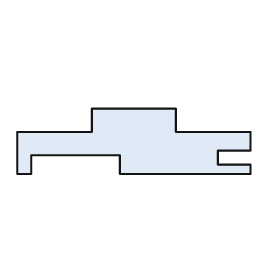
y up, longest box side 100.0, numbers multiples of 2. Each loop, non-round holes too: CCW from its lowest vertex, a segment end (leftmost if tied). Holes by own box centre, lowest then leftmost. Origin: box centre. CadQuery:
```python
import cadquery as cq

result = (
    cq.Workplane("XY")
    .moveTo(-50.0, -14.0)
    .lineTo(-44.0, -14.0)
    .lineTo(-44.0, -6.0)
    .lineTo(-6.0, -6.0)
    .lineTo(-6.0, -14.0)
    .lineTo(50.0, -14.0)
    .lineTo(50.0, -10.0)
    .lineTo(36.0, -10.0)
    .lineTo(36.0, -4.0)
    .lineTo(50.0, -4.0)
    .lineTo(50.0, 4.0)
    .lineTo(18.0, 4.0)
    .lineTo(18.0, 14.0)
    .lineTo(-18.0, 14.0)
    .lineTo(-18.0, 4.0)
    .lineTo(-50.0, 4.0)
    .close()
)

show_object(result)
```